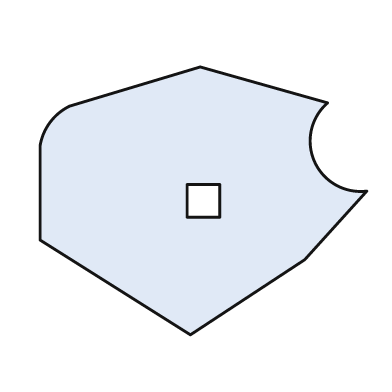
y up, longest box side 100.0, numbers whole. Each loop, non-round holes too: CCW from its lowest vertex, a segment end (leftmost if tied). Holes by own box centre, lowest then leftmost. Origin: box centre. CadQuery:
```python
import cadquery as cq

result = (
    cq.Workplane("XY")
    .moveTo(-4.0, -41.0)
    .lineTo(31.0, -18.0)
    .lineTo(50.0, 3.0)
    .threePointArc((34.0, 12.0), (38.0, 30.0))
    .lineTo(-1.0, 41.0)
    .lineTo(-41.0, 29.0)
    .threePointArc((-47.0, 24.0), (-50.0, 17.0))
    .lineTo(-50.0, -12.0)
    .close()
    .moveTo(-5.0, -5.0)
    .lineTo(5.0, -5.0)
    .lineTo(5.0, 5.0)
    .lineTo(-5.0, 5.0)
    .close()
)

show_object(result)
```